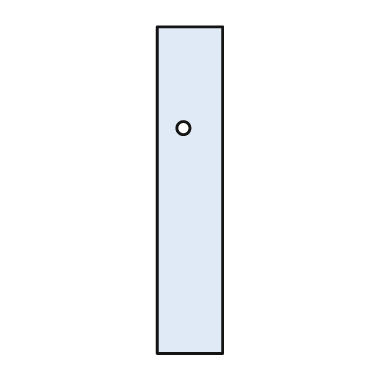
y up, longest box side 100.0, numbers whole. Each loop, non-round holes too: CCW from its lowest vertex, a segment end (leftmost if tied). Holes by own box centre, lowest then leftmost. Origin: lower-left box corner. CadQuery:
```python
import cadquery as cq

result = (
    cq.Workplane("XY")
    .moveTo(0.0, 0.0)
    .lineTo(20.0, 0.0)
    .lineTo(20.0, 100.0)
    .lineTo(0.0, 100.0)
    .close()
    .moveTo(8.0, 69.0)
    .circle(2.0)
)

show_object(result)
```